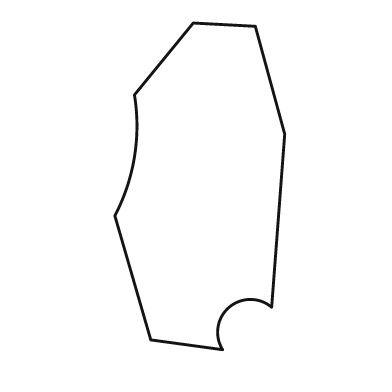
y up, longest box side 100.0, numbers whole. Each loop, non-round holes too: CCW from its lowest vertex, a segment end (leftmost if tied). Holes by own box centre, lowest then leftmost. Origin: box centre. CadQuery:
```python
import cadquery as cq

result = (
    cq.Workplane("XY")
    .moveTo(7.0, -50.0)
    .threePointArc((9.0, -37.0), (22.0, -37.0))
    .lineTo(26.0, 16.0)
    .lineTo(17.0, 49.0)
    .lineTo(-2.0, 50.0)
    .lineTo(-20.0, 28.0)
    .threePointArc((-20.0, 9.0), (-26.0, -9.0))
    .lineTo(-15.0, -47.0)
    .close()
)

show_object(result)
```